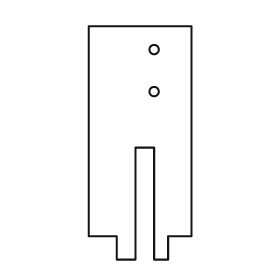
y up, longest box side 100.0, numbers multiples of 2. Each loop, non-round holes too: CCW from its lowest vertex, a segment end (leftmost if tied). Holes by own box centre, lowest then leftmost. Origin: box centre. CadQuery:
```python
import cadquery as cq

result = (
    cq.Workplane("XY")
    .moveTo(-10.0, -50.0)
    .lineTo(-2.0, -50.0)
    .lineTo(-2.0, -2.0)
    .lineTo(6.0, -2.0)
    .lineTo(6.0, -50.0)
    .lineTo(12.0, -50.0)
    .lineTo(12.0, -40.0)
    .lineTo(22.0, -40.0)
    .lineTo(22.0, 50.0)
    .lineTo(-22.0, 50.0)
    .lineTo(-22.0, -40.0)
    .lineTo(-10.0, -40.0)
    .close()
    .moveTo(6.0, 22.0)
    .circle(2.0)
    .moveTo(6.0, 40.0)
    .circle(2.0)
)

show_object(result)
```